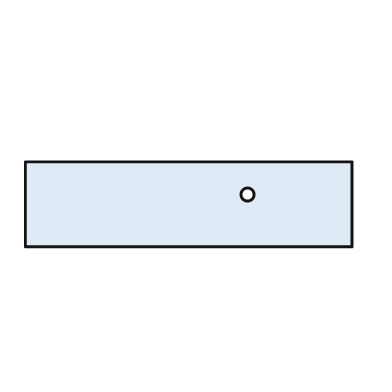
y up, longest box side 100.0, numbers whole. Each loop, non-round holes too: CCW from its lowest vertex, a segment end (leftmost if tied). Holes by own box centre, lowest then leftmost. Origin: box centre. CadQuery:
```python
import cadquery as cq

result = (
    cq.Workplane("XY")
    .moveTo(-50.0, -13.0)
    .lineTo(50.0, -13.0)
    .lineTo(50.0, 13.0)
    .lineTo(-50.0, 13.0)
    .close()
    .moveTo(18.0, 3.0)
    .circle(2.0)
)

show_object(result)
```